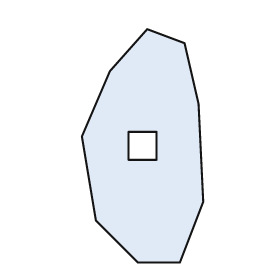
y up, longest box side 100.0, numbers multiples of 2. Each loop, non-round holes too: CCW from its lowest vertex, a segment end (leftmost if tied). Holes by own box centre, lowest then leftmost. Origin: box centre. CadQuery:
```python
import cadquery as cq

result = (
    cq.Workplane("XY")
    .moveTo(-2.0, -50.0)
    .lineTo(16.0, -50.0)
    .lineTo(26.0, -24.0)
    .lineTo(24.0, 18.0)
    .lineTo(18.0, 44.0)
    .lineTo(2.0, 50.0)
    .lineTo(-14.0, 32.0)
    .lineTo(-26.0, 4.0)
    .lineTo(-20.0, -32.0)
    .close()
    .moveTo(-6.0, -6.0)
    .lineTo(6.0, -6.0)
    .lineTo(6.0, 6.0)
    .lineTo(-6.0, 6.0)
    .close()
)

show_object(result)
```